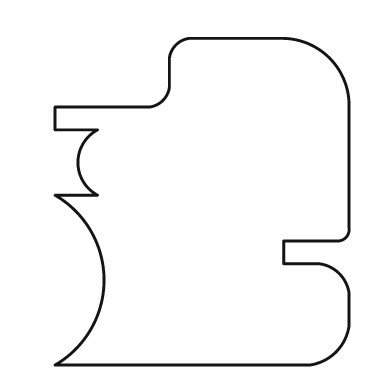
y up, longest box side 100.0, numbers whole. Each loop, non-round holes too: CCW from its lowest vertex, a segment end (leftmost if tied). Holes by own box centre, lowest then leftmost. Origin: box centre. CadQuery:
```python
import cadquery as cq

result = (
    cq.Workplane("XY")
    .moveTo(-45.0, -50.0)
    .lineTo(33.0, -50.0)
    .threePointArc((41.0, -46.0), (45.0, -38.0))
    .lineTo(45.0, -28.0)
    .threePointArc((42.0, -22.0), (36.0, -19.0))
    .lineTo(25.0, -19.0)
    .lineTo(25.0, -12.0)
    .lineTo(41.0, -12.0)
    .threePointArc((44.0, -11.0), (45.0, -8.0))
    .lineTo(45.0, 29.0)
    .threePointArc((39.0, 44.0), (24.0, 50.0))
    .lineTo(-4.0, 50.0)
    .threePointArc((-8.0, 48.0), (-10.0, 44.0))
    .lineTo(-10.0, 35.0)
    .threePointArc((-12.0, 31.0), (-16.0, 29.0))
    .lineTo(-45.0, 29.0)
    .lineTo(-45.0, 22.0)
    .lineTo(-32.0, 22.0)
    .threePointArc((-38.0, 12.0), (-32.0, 2.0))
    .lineTo(-45.0, 2.0)
    .threePointArc((-30.0, -24.0), (-45.0, -50.0))
    .close()
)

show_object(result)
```